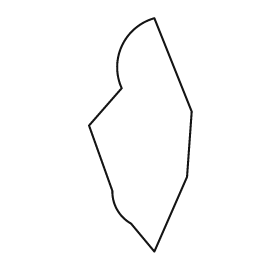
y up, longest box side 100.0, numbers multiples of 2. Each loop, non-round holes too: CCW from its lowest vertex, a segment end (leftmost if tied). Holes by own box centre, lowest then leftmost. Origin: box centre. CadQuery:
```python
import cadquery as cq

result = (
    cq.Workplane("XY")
    .moveTo(6.0, -50.0)
    .lineTo(20.0, -18.0)
    .lineTo(22.0, 10.0)
    .lineTo(6.0, 50.0)
    .threePointArc((-8.0, 38.0), (-8.0, 20.0))
    .lineTo(-22.0, 4.0)
    .lineTo(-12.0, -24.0)
    .threePointArc((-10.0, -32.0), (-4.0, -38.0))
    .close()
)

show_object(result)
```